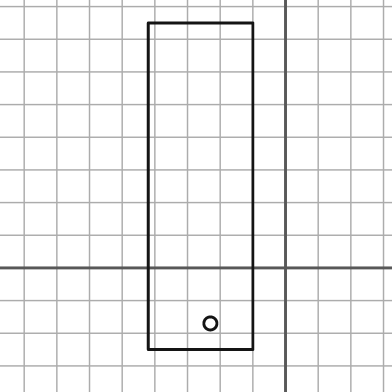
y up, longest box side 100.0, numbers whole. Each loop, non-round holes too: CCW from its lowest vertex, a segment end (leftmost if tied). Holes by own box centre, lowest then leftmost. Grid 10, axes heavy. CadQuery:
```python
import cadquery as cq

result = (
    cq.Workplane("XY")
    .moveTo(-42.0, -25.0)
    .lineTo(-10.0, -25.0)
    .lineTo(-10.0, 75.0)
    .lineTo(-42.0, 75.0)
    .close()
    .moveTo(-23.0, -17.0)
    .circle(2.0)
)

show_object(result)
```